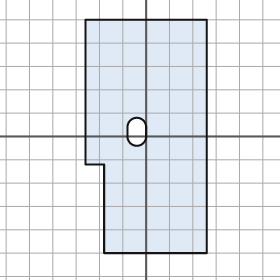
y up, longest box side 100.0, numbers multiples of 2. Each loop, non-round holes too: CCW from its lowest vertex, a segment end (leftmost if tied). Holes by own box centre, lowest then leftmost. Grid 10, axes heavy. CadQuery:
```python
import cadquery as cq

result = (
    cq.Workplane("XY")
    .moveTo(-18.0, -50.0)
    .lineTo(26.0, -50.0)
    .lineTo(26.0, 50.0)
    .lineTo(-26.0, 50.0)
    .lineTo(-26.0, -12.0)
    .lineTo(-18.0, -12.0)
    .close()
    .moveTo(-8.0, 0.0)
    .threePointArc((-4.0, -4.0), (0.0, 0.0))
    .lineTo(0.0, 4.0)
    .threePointArc((-4.0, 8.0), (-8.0, 4.0))
    .close()
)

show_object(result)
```